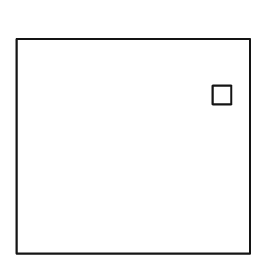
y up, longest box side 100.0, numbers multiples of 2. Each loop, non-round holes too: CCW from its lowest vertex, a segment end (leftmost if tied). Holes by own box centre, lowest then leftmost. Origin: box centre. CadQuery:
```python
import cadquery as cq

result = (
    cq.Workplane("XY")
    .moveTo(-50.0, -46.0)
    .lineTo(50.0, -46.0)
    .lineTo(50.0, 46.0)
    .lineTo(-50.0, 46.0)
    .close()
    .moveTo(34.0, 18.0)
    .lineTo(42.0, 18.0)
    .lineTo(42.0, 26.0)
    .lineTo(34.0, 26.0)
    .close()
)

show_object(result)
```